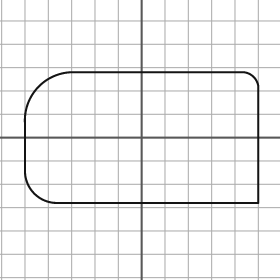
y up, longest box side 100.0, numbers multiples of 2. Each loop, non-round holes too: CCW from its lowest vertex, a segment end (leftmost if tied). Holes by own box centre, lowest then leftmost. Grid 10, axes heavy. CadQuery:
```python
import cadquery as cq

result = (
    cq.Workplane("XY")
    .moveTo(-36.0, -28.0)
    .lineTo(50.0, -28.0)
    .lineTo(50.0, 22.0)
    .threePointArc((48.0, 26.0), (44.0, 28.0))
    .lineTo(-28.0, 28.0)
    .threePointArc((-44.0, 22.0), (-50.0, 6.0))
    .lineTo(-50.0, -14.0)
    .threePointArc((-46.0, -24.0), (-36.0, -28.0))
    .close()
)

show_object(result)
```